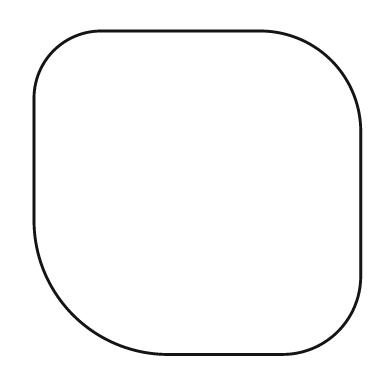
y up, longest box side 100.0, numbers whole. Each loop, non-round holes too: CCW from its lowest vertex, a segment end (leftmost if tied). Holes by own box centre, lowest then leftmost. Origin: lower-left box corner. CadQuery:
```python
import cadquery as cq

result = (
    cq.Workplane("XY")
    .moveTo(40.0, 0.0)
    .lineTo(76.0, 0.0)
    .threePointArc((93.0, 7.0), (100.0, 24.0))
    .lineTo(100.0, 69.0)
    .threePointArc((91.0, 90.0), (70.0, 99.0))
    .lineTo(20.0, 99.0)
    .threePointArc((6.0, 93.0), (0.0, 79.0))
    .lineTo(0.0, 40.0)
    .threePointArc((12.0, 12.0), (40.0, 0.0))
    .close()
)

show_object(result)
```